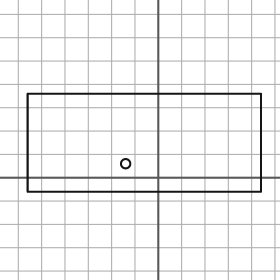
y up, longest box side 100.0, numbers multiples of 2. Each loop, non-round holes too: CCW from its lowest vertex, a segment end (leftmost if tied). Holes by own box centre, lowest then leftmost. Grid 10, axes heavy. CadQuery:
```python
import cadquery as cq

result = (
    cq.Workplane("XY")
    .moveTo(-56.0, -6.0)
    .lineTo(44.0, -6.0)
    .lineTo(44.0, 36.0)
    .lineTo(-56.0, 36.0)
    .close()
    .moveTo(-14.0, 6.0)
    .circle(2.0)
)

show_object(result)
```